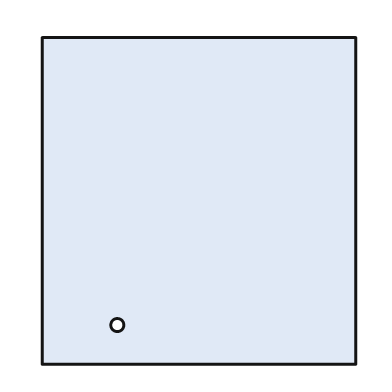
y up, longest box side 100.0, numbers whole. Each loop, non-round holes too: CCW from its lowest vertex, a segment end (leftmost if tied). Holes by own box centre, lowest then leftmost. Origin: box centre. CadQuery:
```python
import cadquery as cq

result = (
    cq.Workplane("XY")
    .moveTo(-48.0, -50.0)
    .lineTo(48.0, -50.0)
    .lineTo(48.0, 50.0)
    .lineTo(-48.0, 50.0)
    .close()
    .moveTo(-25.0, -38.0)
    .circle(2.0)
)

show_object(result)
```